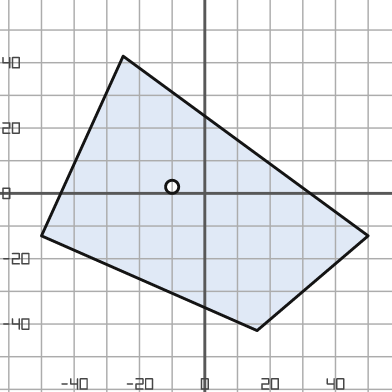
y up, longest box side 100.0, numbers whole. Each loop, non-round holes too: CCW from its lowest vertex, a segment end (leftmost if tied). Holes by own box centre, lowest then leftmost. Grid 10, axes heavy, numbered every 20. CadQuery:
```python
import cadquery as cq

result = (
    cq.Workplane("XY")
    .moveTo(16.0, -42.0)
    .lineTo(50.0, -13.0)
    .lineTo(-25.0, 42.0)
    .lineTo(-50.0, -13.0)
    .close()
    .moveTo(-10.0, 2.0)
    .circle(2.0)
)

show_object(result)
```